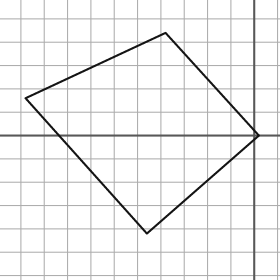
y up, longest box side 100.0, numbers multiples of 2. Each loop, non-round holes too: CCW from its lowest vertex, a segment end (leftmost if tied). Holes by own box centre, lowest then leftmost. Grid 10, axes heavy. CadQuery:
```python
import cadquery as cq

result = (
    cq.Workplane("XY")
    .moveTo(-46.0, -42.0)
    .lineTo(2.0, 0.0)
    .lineTo(-38.0, 44.0)
    .lineTo(-98.0, 16.0)
    .close()
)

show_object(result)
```